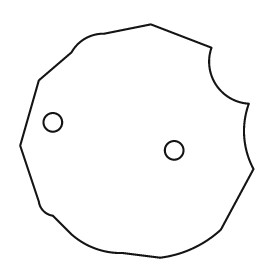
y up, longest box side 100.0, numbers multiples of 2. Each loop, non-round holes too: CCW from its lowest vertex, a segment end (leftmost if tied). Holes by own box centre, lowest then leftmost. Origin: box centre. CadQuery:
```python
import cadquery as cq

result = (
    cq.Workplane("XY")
    .moveTo(10.0, -50.0)
    .threePointArc((24.0, -46.0), (36.0, -38.0))
    .lineTo(50.0, -12.0)
    .threePointArc((46.0, 2.0), (48.0, 16.0))
    .threePointArc((34.0, 24.0), (32.0, 40.0))
    .lineTo(6.0, 50.0)
    .lineTo(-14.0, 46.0)
    .threePointArc((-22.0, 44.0), (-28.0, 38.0))
    .lineTo(-42.0, 26.0)
    .lineTo(-50.0, -2.0)
    .lineTo(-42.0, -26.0)
    .threePointArc((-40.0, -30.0), (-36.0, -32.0))
    .lineTo(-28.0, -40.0)
    .threePointArc((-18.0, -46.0), (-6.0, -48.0))
    .close()
    .moveTo(16.0, -4.0)
    .circle(4.0)
    .moveTo(-36.0, 8.0)
    .circle(4.0)
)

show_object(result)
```